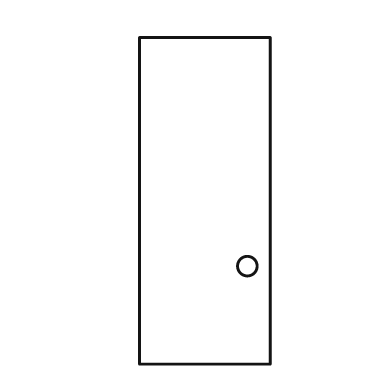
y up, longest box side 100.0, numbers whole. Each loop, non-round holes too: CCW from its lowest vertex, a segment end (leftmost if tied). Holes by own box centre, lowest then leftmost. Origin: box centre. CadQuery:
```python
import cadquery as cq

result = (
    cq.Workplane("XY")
    .moveTo(-20.0, -50.0)
    .lineTo(20.0, -50.0)
    .lineTo(20.0, 50.0)
    .lineTo(-20.0, 50.0)
    .close()
    .moveTo(13.0, -20.0)
    .circle(3.0)
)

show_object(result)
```